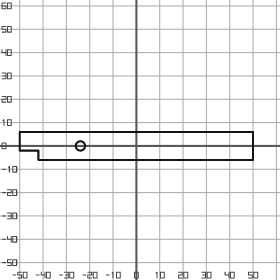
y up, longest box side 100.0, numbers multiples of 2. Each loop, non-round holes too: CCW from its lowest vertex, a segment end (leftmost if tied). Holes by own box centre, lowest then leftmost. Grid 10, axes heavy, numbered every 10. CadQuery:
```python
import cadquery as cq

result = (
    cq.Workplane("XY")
    .moveTo(-42.0, -6.0)
    .lineTo(50.0, -6.0)
    .lineTo(50.0, 6.0)
    .lineTo(-50.0, 6.0)
    .lineTo(-50.0, -2.0)
    .lineTo(-42.0, -2.0)
    .close()
    .moveTo(-24.0, 0.0)
    .circle(2.0)
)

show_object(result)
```